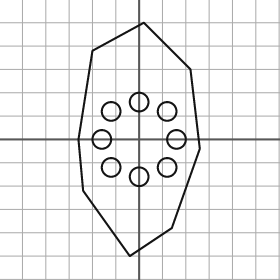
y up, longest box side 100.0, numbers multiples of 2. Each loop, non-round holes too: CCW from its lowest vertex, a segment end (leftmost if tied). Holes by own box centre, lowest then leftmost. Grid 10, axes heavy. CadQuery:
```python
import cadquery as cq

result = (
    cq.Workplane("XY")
    .moveTo(-4.0, -50.0)
    .lineTo(14.0, -38.0)
    .lineTo(26.0, -4.0)
    .lineTo(22.0, 30.0)
    .lineTo(2.0, 50.0)
    .lineTo(-20.0, 38.0)
    .lineTo(-26.0, 0.0)
    .lineTo(-24.0, -22.0)
    .close()
    .moveTo(0.0, -16.0)
    .circle(4.0)
    .moveTo(-12.0, -12.0)
    .circle(4.0)
    .moveTo(12.0, -12.0)
    .circle(4.0)
    .moveTo(-16.0, 0.0)
    .circle(4.0)
    .moveTo(16.0, 0.0)
    .circle(4.0)
    .moveTo(-12.0, 12.0)
    .circle(4.0)
    .moveTo(12.0, 12.0)
    .circle(4.0)
    .moveTo(0.0, 16.0)
    .circle(4.0)
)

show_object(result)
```